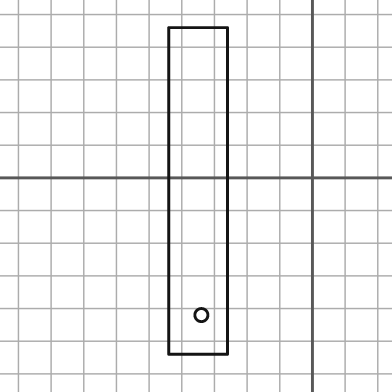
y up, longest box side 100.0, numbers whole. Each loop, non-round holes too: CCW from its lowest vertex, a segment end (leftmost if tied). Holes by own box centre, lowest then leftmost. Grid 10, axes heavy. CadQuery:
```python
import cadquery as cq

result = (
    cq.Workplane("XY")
    .moveTo(-44.0, -54.0)
    .lineTo(-26.0, -54.0)
    .lineTo(-26.0, 46.0)
    .lineTo(-44.0, 46.0)
    .close()
    .moveTo(-34.0, -42.0)
    .circle(2.0)
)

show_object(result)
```